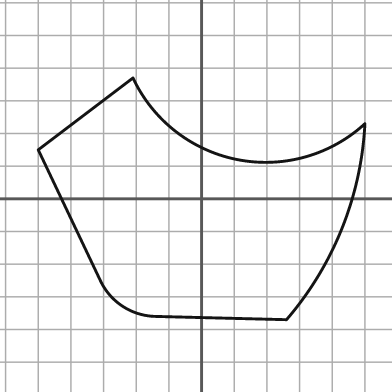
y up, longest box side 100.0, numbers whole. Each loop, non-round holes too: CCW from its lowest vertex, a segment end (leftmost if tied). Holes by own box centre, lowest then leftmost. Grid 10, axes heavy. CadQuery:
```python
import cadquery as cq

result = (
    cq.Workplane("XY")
    .moveTo(26.0, -37.0)
    .threePointArc((43.0, -9.0), (50.0, 23.0))
    .threePointArc((11.0, 12.0), (-21.0, 37.0))
    .lineTo(-50.0, 15.0)
    .lineTo(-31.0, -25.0)
    .threePointArc((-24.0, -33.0), (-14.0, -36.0))
    .close()
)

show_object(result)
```